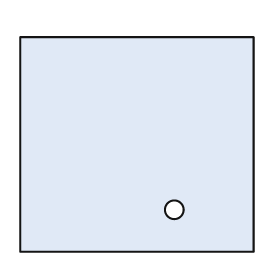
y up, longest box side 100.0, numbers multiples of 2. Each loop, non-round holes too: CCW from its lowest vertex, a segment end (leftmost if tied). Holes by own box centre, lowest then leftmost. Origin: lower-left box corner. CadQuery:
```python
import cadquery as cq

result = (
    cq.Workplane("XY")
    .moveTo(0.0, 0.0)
    .lineTo(100.0, 0.0)
    .lineTo(100.0, 92.0)
    .lineTo(0.0, 92.0)
    .close()
    .moveTo(66.0, 18.0)
    .circle(4.0)
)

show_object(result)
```